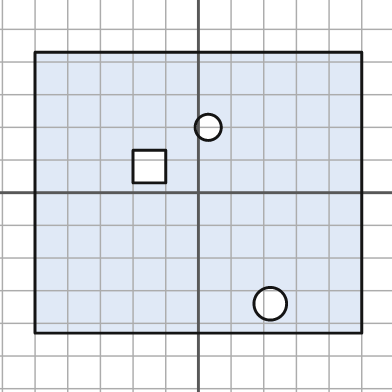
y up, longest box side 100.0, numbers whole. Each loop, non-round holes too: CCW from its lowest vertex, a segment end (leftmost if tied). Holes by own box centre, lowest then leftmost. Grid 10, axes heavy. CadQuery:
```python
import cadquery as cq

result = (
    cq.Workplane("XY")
    .moveTo(-50.0, -43.0)
    .lineTo(50.0, -43.0)
    .lineTo(50.0, 43.0)
    .lineTo(-50.0, 43.0)
    .close()
    .moveTo(22.0, -34.0)
    .circle(5.0)
    .moveTo(-20.0, 3.0)
    .lineTo(-10.0, 3.0)
    .lineTo(-10.0, 13.0)
    .lineTo(-20.0, 13.0)
    .close()
    .moveTo(3.0, 20.0)
    .circle(4.0)
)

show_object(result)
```